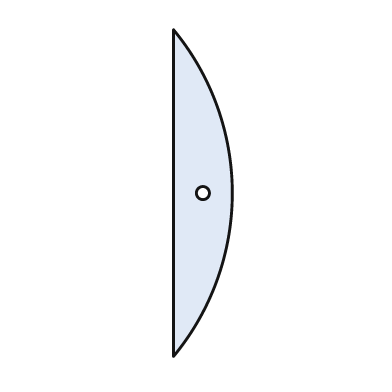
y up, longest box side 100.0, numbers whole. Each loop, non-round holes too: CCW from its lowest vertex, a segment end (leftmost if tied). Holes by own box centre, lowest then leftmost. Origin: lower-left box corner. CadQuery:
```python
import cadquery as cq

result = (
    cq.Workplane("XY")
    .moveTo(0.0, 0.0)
    .threePointArc((18.0, 50.0), (0.0, 100.0))
    .close()
    .moveTo(9.0, 50.0)
    .circle(2.0)
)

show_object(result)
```